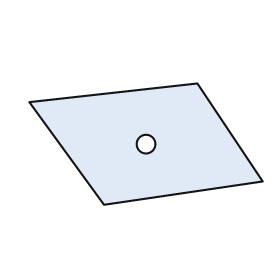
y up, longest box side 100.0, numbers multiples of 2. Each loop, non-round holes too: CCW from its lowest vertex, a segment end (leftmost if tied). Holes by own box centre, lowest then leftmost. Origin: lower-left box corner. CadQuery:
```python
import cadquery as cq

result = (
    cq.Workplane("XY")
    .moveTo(32.0, 0.0)
    .lineTo(100.0, 10.0)
    .lineTo(72.0, 52.0)
    .lineTo(0.0, 44.0)
    .close()
    .moveTo(50.0, 26.0)
    .circle(4.0)
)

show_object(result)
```